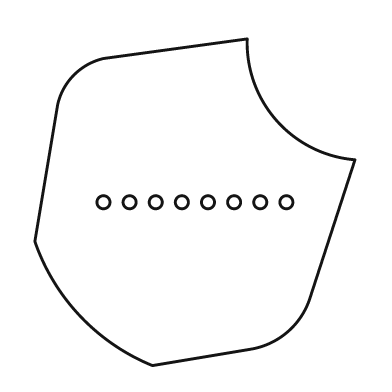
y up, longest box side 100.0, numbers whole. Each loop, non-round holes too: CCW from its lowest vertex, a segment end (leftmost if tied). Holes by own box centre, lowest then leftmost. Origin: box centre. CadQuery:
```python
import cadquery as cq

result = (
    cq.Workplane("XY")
    .moveTo(-13.0, -50.0)
    .lineTo(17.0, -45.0)
    .threePointArc((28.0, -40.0), (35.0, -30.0))
    .lineTo(49.0, 13.0)
    .threePointArc((25.0, 25.0), (16.0, 50.0))
    .lineTo(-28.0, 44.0)
    .threePointArc((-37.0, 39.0), (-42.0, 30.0))
    .lineTo(-49.0, -12.0)
    .threePointArc((-35.0, -35.0), (-13.0, -50.0))
    .close()
    .moveTo(-28.0, 0.0)
    .circle(2.0)
    .moveTo(-20.0, 0.0)
    .circle(2.0)
    .moveTo(-12.0, 0.0)
    .circle(2.0)
    .moveTo(-4.0, 0.0)
    .circle(2.0)
    .moveTo(4.0, 0.0)
    .circle(2.0)
    .moveTo(12.0, 0.0)
    .circle(2.0)
    .moveTo(20.0, 0.0)
    .circle(2.0)
    .moveTo(28.0, 0.0)
    .circle(2.0)
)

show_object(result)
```